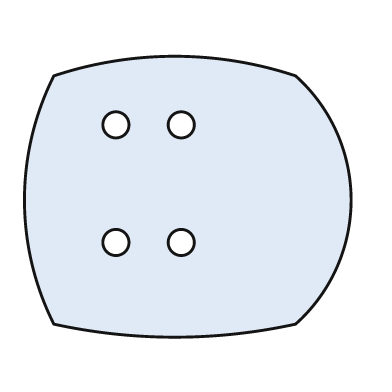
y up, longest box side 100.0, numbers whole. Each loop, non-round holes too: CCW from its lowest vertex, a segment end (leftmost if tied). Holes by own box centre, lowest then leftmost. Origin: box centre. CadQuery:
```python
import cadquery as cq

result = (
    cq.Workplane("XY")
    .moveTo(-41.0, -39.0)
    .threePointArc((-4.0, -43.0), (33.0, -39.0))
    .threePointArc((50.0, -1.0), (33.0, 37.0))
    .threePointArc((-4.0, 43.0), (-41.0, 37.0))
    .threePointArc((-50.0, -1.0), (-41.0, -39.0))
    .close()
    .moveTo(-22.0, -14.0)
    .circle(4.0)
    .moveTo(-2.0, -14.0)
    .circle(4.0)
    .moveTo(-22.0, 22.0)
    .circle(4.0)
    .moveTo(-2.0, 22.0)
    .circle(4.0)
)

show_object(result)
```